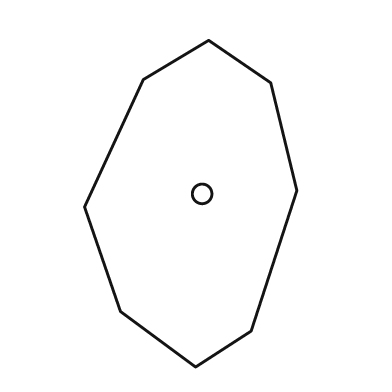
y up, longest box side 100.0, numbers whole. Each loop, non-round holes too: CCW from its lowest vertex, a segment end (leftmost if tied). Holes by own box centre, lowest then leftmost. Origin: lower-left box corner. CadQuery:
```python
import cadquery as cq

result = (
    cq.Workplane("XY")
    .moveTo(34.0, 0.0)
    .lineTo(51.0, 11.0)
    .lineTo(65.0, 54.0)
    .lineTo(57.0, 87.0)
    .lineTo(38.0, 100.0)
    .lineTo(18.0, 88.0)
    .lineTo(0.0, 49.0)
    .lineTo(11.0, 17.0)
    .close()
    .moveTo(36.0, 53.0)
    .circle(3.0)
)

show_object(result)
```